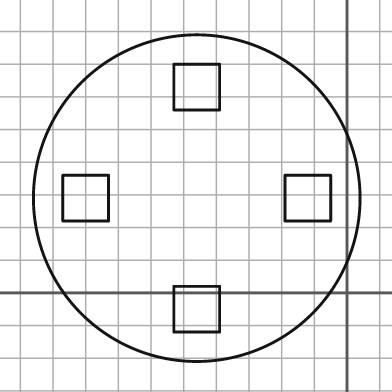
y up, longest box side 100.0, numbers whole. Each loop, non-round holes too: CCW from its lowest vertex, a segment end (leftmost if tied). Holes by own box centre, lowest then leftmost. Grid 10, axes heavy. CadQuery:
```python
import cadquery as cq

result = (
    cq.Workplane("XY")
    .moveTo(-46.0, 29.0)
    .circle(50.0)
    .moveTo(-53.0, -12.0)
    .lineTo(-39.0, -12.0)
    .lineTo(-39.0, 2.0)
    .lineTo(-53.0, 2.0)
    .close()
    .moveTo(-87.0, 22.0)
    .lineTo(-73.0, 22.0)
    .lineTo(-73.0, 36.0)
    .lineTo(-87.0, 36.0)
    .close()
    .moveTo(-19.0, 22.0)
    .lineTo(-5.0, 22.0)
    .lineTo(-5.0, 36.0)
    .lineTo(-19.0, 36.0)
    .close()
    .moveTo(-53.0, 56.0)
    .lineTo(-39.0, 56.0)
    .lineTo(-39.0, 70.0)
    .lineTo(-53.0, 70.0)
    .close()
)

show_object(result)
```